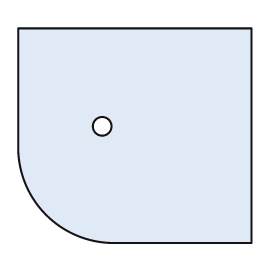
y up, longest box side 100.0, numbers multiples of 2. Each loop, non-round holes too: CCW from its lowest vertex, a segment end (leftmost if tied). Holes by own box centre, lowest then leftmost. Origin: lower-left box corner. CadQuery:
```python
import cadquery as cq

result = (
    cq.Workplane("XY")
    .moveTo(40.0, 0.0)
    .lineTo(100.0, 0.0)
    .lineTo(100.0, 92.0)
    .lineTo(0.0, 92.0)
    .lineTo(0.0, 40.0)
    .threePointArc((12.0, 12.0), (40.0, 0.0))
    .close()
    .moveTo(36.0, 50.0)
    .circle(4.0)
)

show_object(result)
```